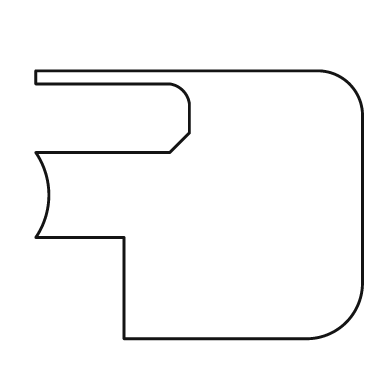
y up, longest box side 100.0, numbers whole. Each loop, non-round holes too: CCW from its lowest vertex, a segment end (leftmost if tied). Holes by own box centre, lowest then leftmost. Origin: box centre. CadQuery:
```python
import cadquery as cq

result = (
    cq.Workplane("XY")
    .moveTo(-23.0, -41.0)
    .lineTo(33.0, -41.0)
    .threePointArc((45.0, -36.0), (50.0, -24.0))
    .lineTo(50.0, 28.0)
    .threePointArc((46.0, 37.0), (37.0, 41.0))
    .lineTo(-50.0, 41.0)
    .lineTo(-50.0, 37.0)
    .lineTo(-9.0, 37.0)
    .threePointArc((-5.0, 35.0), (-3.0, 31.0))
    .lineTo(-3.0, 22.0)
    .lineTo(-9.0, 16.0)
    .lineTo(-50.0, 16.0)
    .threePointArc((-46.0, 3.0), (-50.0, -10.0))
    .lineTo(-23.0, -10.0)
    .close()
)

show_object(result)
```